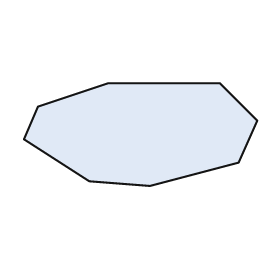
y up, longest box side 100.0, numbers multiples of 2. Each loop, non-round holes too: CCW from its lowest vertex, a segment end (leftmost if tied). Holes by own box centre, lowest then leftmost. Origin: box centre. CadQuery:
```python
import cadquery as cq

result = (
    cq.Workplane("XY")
    .moveTo(4.0, -22.0)
    .lineTo(42.0, -12.0)
    .lineTo(50.0, 6.0)
    .lineTo(34.0, 22.0)
    .lineTo(-14.0, 22.0)
    .lineTo(-44.0, 12.0)
    .lineTo(-50.0, -2.0)
    .lineTo(-22.0, -20.0)
    .close()
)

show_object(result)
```